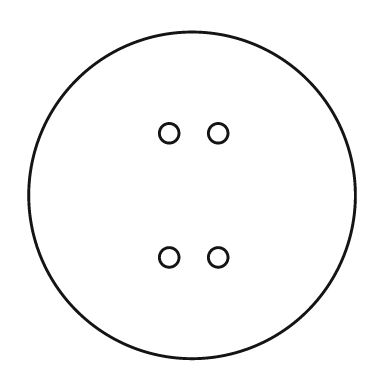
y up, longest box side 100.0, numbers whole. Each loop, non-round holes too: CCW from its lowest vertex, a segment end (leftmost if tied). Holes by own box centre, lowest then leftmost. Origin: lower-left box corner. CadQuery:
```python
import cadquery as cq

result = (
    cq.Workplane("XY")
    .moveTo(50.0, 50.0)
    .circle(50.0)
    .moveTo(43.0, 31.0)
    .circle(3.0)
    .moveTo(58.0, 31.0)
    .circle(3.0)
    .moveTo(43.0, 69.0)
    .circle(3.0)
    .moveTo(58.0, 69.0)
    .circle(3.0)
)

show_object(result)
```